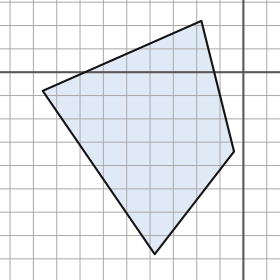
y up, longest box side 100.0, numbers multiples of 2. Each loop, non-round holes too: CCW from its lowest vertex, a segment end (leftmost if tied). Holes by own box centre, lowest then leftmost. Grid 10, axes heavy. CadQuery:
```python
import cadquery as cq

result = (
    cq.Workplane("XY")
    .moveTo(-38.0, -78.0)
    .lineTo(-4.0, -34.0)
    .lineTo(-18.0, 22.0)
    .lineTo(-86.0, -8.0)
    .close()
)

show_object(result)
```